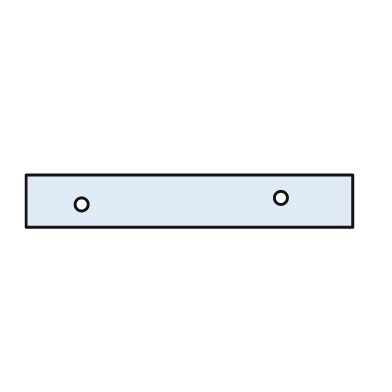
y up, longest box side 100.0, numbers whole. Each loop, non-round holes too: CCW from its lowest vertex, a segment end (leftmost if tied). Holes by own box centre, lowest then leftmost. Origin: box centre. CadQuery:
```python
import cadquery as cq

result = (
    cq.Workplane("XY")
    .moveTo(-50.0, -8.0)
    .lineTo(50.0, -8.0)
    .lineTo(50.0, 8.0)
    .lineTo(-50.0, 8.0)
    .close()
    .moveTo(-33.0, -1.0)
    .circle(2.0)
    .moveTo(28.0, 1.0)
    .circle(2.0)
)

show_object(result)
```